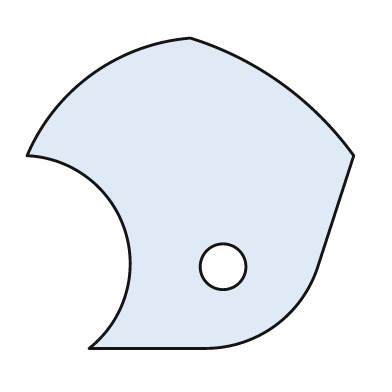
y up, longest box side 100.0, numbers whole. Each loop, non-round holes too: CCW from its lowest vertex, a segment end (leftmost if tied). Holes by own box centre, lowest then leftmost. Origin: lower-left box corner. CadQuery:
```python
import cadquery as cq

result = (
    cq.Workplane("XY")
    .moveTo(19.0, 0.0)
    .lineTo(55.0, 0.0)
    .threePointArc((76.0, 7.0), (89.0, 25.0))
    .lineTo(100.0, 59.0)
    .threePointArc((78.0, 81.0), (50.0, 95.0))
    .threePointArc((20.0, 84.0), (0.0, 59.0))
    .threePointArc((30.0, 36.0), (19.0, 0.0))
    .close()
    .moveTo(60.0, 25.0)
    .circle(7.0)
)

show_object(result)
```